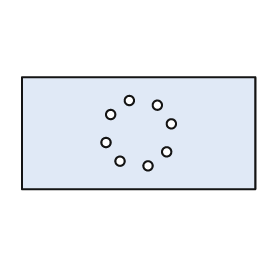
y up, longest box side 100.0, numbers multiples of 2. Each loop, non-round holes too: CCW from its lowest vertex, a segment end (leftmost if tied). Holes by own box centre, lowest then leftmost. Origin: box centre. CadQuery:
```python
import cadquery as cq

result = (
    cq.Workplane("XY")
    .moveTo(-50.0, -24.0)
    .lineTo(50.0, -24.0)
    .lineTo(50.0, 24.0)
    .lineTo(-50.0, 24.0)
    .close()
    .moveTo(4.0, -14.0)
    .circle(2.0)
    .moveTo(-8.0, -12.0)
    .circle(2.0)
    .moveTo(12.0, -8.0)
    .circle(2.0)
    .moveTo(-14.0, -4.0)
    .circle(2.0)
    .moveTo(14.0, 4.0)
    .circle(2.0)
    .moveTo(-12.0, 8.0)
    .circle(2.0)
    .moveTo(8.0, 12.0)
    .circle(2.0)
    .moveTo(-4.0, 14.0)
    .circle(2.0)
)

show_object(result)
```